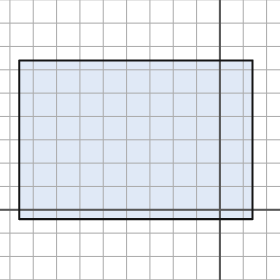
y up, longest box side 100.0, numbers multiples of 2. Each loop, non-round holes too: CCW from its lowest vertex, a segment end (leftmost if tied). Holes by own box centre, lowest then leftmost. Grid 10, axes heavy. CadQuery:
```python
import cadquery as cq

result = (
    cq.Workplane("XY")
    .moveTo(-86.0, -4.0)
    .lineTo(14.0, -4.0)
    .lineTo(14.0, 64.0)
    .lineTo(-86.0, 64.0)
    .close()
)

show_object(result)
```